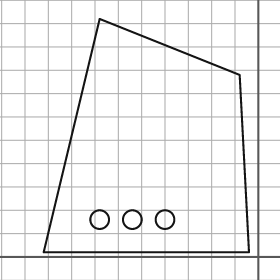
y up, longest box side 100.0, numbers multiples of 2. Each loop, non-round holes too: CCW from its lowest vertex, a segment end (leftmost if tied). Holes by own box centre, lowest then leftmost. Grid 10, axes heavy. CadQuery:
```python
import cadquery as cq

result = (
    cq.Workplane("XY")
    .moveTo(-92.0, 2.0)
    .lineTo(-4.0, 2.0)
    .lineTo(-8.0, 78.0)
    .lineTo(-68.0, 102.0)
    .close()
    .moveTo(-68.0, 16.0)
    .circle(4.0)
    .moveTo(-54.0, 16.0)
    .circle(4.0)
    .moveTo(-40.0, 16.0)
    .circle(4.0)
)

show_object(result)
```